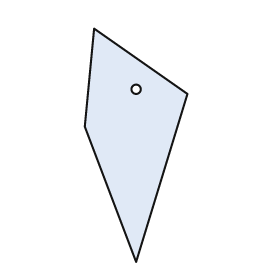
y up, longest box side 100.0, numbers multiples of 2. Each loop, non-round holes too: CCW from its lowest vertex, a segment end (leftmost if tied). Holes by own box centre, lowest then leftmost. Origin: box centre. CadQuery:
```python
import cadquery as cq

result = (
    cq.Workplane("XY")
    .moveTo(0.0, -50.0)
    .lineTo(22.0, 22.0)
    .lineTo(-18.0, 50.0)
    .lineTo(-22.0, 8.0)
    .close()
    .moveTo(0.0, 24.0)
    .circle(2.0)
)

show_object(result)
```